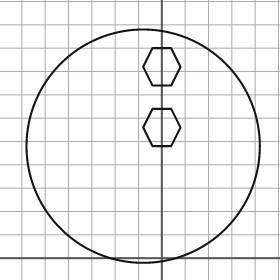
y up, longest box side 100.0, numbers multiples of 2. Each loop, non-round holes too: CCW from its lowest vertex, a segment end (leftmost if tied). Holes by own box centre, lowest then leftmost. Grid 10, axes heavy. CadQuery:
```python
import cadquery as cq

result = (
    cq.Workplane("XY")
    .moveTo(-8.0, 48.0)
    .circle(50.0)
    .moveTo(-4.0, 48.0)
    .lineTo(4.0, 48.0)
    .lineTo(8.0, 56.0)
    .lineTo(4.0, 64.0)
    .lineTo(-4.0, 64.0)
    .lineTo(-8.0, 56.0)
    .close()
    .moveTo(-4.0, 74.0)
    .lineTo(4.0, 74.0)
    .lineTo(8.0, 82.0)
    .lineTo(4.0, 90.0)
    .lineTo(-4.0, 90.0)
    .lineTo(-8.0, 82.0)
    .close()
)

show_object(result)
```